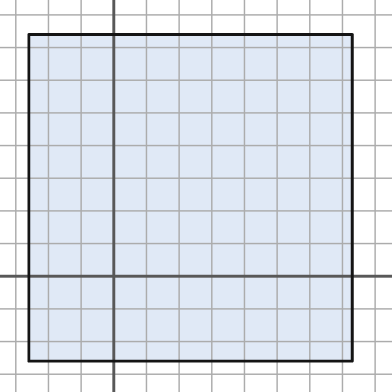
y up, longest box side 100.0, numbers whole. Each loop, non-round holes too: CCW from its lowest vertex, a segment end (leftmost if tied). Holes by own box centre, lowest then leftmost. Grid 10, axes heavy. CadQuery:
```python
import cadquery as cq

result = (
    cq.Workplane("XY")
    .moveTo(-26.0, -26.0)
    .lineTo(73.0, -26.0)
    .lineTo(73.0, 74.0)
    .lineTo(-26.0, 74.0)
    .close()
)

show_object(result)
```